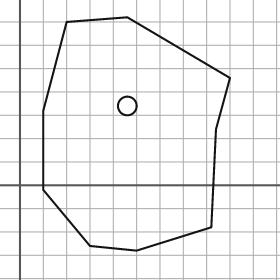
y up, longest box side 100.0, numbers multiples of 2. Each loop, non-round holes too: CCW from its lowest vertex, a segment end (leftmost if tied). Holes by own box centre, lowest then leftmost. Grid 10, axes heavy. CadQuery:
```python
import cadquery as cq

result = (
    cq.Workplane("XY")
    .moveTo(50.0, -28.0)
    .lineTo(82.0, -18.0)
    .lineTo(84.0, 24.0)
    .lineTo(90.0, 46.0)
    .lineTo(46.0, 72.0)
    .lineTo(20.0, 70.0)
    .lineTo(10.0, 32.0)
    .lineTo(10.0, -2.0)
    .lineTo(30.0, -26.0)
    .close()
    .moveTo(46.0, 34.0)
    .circle(4.0)
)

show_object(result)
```